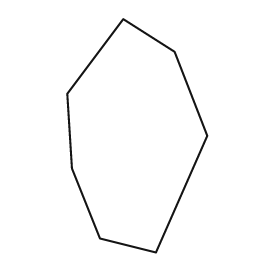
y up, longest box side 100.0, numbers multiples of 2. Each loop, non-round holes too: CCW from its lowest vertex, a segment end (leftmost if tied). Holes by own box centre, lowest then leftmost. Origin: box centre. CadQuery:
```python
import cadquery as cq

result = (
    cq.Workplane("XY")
    .moveTo(8.0, -50.0)
    .lineTo(30.0, 0.0)
    .lineTo(16.0, 36.0)
    .lineTo(-6.0, 50.0)
    .lineTo(-30.0, 18.0)
    .lineTo(-28.0, -14.0)
    .lineTo(-16.0, -44.0)
    .close()
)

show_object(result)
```